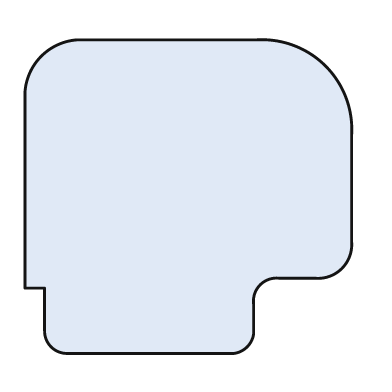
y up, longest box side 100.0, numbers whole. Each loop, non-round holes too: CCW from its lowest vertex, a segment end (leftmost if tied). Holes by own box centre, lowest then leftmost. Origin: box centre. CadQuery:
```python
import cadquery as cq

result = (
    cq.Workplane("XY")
    .moveTo(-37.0, -48.0)
    .lineTo(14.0, -48.0)
    .threePointArc((18.0, -46.0), (20.0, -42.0))
    .lineTo(20.0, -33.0)
    .threePointArc((22.0, -27.0), (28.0, -25.0))
    .lineTo(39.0, -25.0)
    .threePointArc((47.0, -22.0), (50.0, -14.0))
    .lineTo(50.0, 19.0)
    .threePointArc((42.0, 40.0), (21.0, 48.0))
    .lineTo(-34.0, 48.0)
    .threePointArc((-45.0, 43.0), (-50.0, 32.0))
    .lineTo(-50.0, -28.0)
    .lineTo(-44.0, -28.0)
    .lineTo(-44.0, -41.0)
    .threePointArc((-42.0, -46.0), (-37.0, -48.0))
    .close()
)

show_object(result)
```